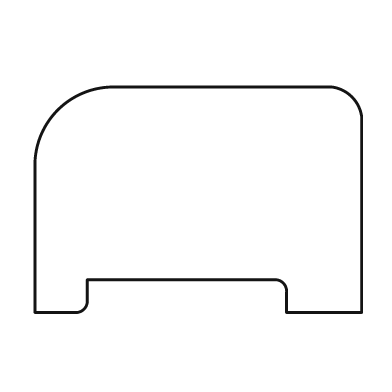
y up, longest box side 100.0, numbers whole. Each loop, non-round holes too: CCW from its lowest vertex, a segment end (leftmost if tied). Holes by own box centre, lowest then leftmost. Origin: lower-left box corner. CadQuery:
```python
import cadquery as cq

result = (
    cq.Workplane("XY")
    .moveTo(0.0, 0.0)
    .lineTo(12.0, 0.0)
    .threePointArc((15.0, 1.0), (16.0, 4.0))
    .lineTo(16.0, 10.0)
    .lineTo(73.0, 10.0)
    .threePointArc((76.0, 9.0), (77.0, 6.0))
    .lineTo(77.0, 0.0)
    .lineTo(100.0, 0.0)
    .lineTo(100.0, 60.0)
    .threePointArc((97.0, 66.0), (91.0, 69.0))
    .lineTo(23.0, 69.0)
    .threePointArc((7.0, 62.0), (0.0, 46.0))
    .close()
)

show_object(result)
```